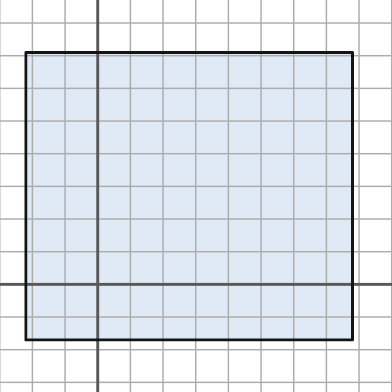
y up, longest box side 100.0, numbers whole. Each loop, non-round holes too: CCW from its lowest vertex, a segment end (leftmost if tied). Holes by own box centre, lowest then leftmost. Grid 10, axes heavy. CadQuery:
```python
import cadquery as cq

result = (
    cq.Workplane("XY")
    .moveTo(-22.0, -17.0)
    .lineTo(78.0, -17.0)
    .lineTo(78.0, 71.0)
    .lineTo(-22.0, 71.0)
    .close()
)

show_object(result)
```